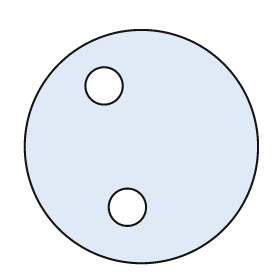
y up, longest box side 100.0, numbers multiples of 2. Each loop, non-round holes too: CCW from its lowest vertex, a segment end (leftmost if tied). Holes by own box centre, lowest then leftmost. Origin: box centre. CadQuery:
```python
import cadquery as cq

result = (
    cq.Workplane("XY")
    .moveTo(0.0, 0.0)
    .circle(50.0)
    .moveTo(-6.0, -26.0)
    .circle(8.0)
    .moveTo(-16.0, 26.0)
    .circle(8.0)
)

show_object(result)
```